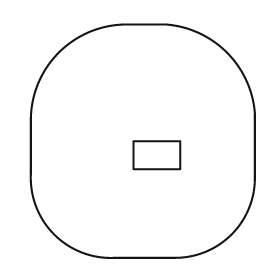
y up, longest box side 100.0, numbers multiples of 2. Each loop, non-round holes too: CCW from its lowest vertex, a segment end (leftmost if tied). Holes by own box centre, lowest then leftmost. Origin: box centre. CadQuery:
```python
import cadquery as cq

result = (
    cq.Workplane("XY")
    .moveTo(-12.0, -50.0)
    .lineTo(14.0, -50.0)
    .threePointArc((38.0, -40.0), (48.0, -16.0))
    .lineTo(48.0, 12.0)
    .threePointArc((36.0, 38.0), (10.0, 50.0))
    .lineTo(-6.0, 50.0)
    .threePointArc((-36.0, 38.0), (-48.0, 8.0))
    .lineTo(-48.0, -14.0)
    .threePointArc((-38.0, -40.0), (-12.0, -50.0))
    .close()
    .moveTo(-4.0, -12.0)
    .lineTo(16.0, -12.0)
    .lineTo(16.0, 0.0)
    .lineTo(-4.0, 0.0)
    .close()
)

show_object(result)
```